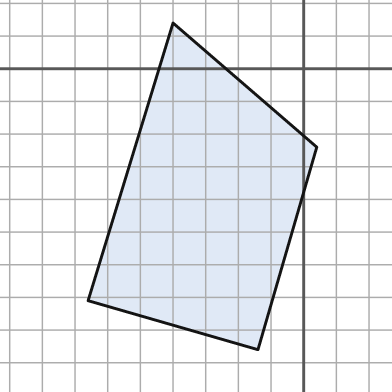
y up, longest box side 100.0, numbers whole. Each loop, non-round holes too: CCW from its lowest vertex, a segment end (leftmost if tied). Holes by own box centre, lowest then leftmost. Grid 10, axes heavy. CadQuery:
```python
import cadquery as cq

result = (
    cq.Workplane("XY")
    .moveTo(-14.0, -86.0)
    .lineTo(4.0, -24.0)
    .lineTo(-40.0, 14.0)
    .lineTo(-66.0, -71.0)
    .close()
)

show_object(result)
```